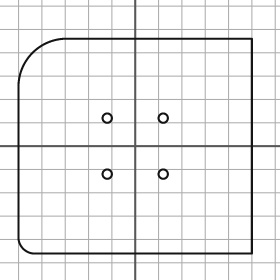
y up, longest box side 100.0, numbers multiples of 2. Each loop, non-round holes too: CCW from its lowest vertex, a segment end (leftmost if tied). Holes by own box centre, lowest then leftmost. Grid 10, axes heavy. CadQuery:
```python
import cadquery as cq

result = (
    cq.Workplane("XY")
    .moveTo(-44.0, -46.0)
    .lineTo(50.0, -46.0)
    .lineTo(50.0, 46.0)
    .lineTo(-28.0, 46.0)
    .threePointArc((-44.0, 40.0), (-50.0, 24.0))
    .lineTo(-50.0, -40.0)
    .threePointArc((-48.0, -44.0), (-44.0, -46.0))
    .close()
    .moveTo(-12.0, -12.0)
    .circle(2.0)
    .moveTo(12.0, -12.0)
    .circle(2.0)
    .moveTo(-12.0, 12.0)
    .circle(2.0)
    .moveTo(12.0, 12.0)
    .circle(2.0)
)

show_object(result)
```